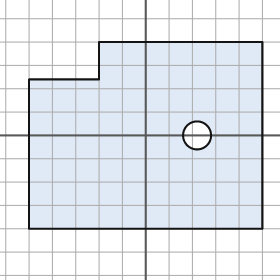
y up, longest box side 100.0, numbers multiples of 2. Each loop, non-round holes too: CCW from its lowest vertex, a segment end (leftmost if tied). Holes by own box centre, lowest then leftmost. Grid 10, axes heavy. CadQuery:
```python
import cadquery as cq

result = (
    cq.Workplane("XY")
    .moveTo(-50.0, -40.0)
    .lineTo(50.0, -40.0)
    .lineTo(50.0, 40.0)
    .lineTo(-20.0, 40.0)
    .lineTo(-20.0, 24.0)
    .lineTo(-50.0, 24.0)
    .close()
    .moveTo(22.0, 0.0)
    .circle(6.0)
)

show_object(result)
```